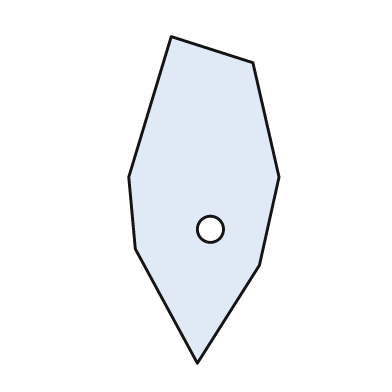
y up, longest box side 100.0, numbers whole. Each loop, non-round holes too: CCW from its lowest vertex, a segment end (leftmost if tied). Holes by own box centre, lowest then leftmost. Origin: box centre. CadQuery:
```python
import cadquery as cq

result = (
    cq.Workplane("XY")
    .moveTo(-2.0, -50.0)
    .lineTo(17.0, -20.0)
    .lineTo(23.0, 7.0)
    .lineTo(15.0, 42.0)
    .lineTo(-10.0, 50.0)
    .lineTo(-23.0, 7.0)
    .lineTo(-21.0, -15.0)
    .close()
    .moveTo(2.0, -9.0)
    .circle(4.0)
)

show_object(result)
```